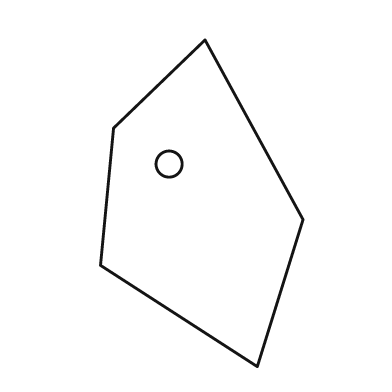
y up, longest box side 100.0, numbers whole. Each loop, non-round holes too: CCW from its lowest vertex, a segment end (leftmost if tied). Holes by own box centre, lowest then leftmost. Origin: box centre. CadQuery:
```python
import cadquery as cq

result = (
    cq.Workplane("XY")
    .moveTo(17.0, -50.0)
    .lineTo(31.0, -5.0)
    .lineTo(1.0, 50.0)
    .lineTo(-27.0, 23.0)
    .lineTo(-31.0, -19.0)
    .close()
    .moveTo(-10.0, 12.0)
    .circle(4.0)
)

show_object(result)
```